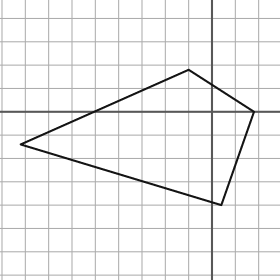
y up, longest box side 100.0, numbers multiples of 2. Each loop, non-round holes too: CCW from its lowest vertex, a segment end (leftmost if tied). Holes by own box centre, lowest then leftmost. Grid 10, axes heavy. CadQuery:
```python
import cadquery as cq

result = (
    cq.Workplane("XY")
    .moveTo(4.0, -40.0)
    .lineTo(18.0, 0.0)
    .lineTo(-10.0, 18.0)
    .lineTo(-82.0, -14.0)
    .close()
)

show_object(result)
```